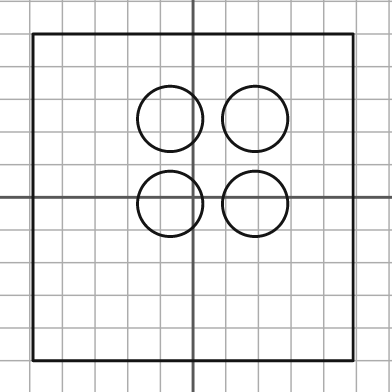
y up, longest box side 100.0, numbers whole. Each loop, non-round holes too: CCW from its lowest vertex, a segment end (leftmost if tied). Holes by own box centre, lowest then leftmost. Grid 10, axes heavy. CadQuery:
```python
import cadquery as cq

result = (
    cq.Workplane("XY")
    .moveTo(-49.0, -50.0)
    .lineTo(49.0, -50.0)
    .lineTo(49.0, 50.0)
    .lineTo(-49.0, 50.0)
    .close()
    .moveTo(-7.0, -2.0)
    .circle(10.0)
    .moveTo(19.0, -2.0)
    .circle(10.0)
    .moveTo(-7.0, 24.0)
    .circle(10.0)
    .moveTo(19.0, 24.0)
    .circle(10.0)
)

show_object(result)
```